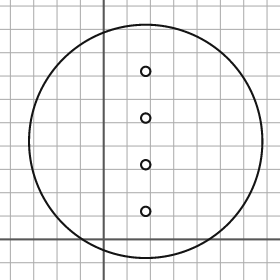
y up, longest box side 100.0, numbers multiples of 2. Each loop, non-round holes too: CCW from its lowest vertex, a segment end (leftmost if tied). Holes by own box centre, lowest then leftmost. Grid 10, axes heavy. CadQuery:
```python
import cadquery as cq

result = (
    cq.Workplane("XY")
    .moveTo(18.0, 42.0)
    .circle(50.0)
    .moveTo(18.0, 12.0)
    .circle(2.0)
    .moveTo(18.0, 32.0)
    .circle(2.0)
    .moveTo(18.0, 52.0)
    .circle(2.0)
    .moveTo(18.0, 72.0)
    .circle(2.0)
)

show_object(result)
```